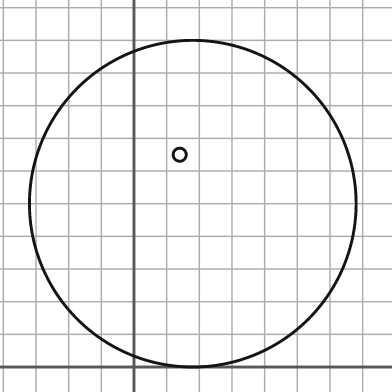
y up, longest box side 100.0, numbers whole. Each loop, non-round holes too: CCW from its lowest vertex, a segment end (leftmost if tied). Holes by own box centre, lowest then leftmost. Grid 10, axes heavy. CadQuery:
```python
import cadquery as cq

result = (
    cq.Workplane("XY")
    .moveTo(18.0, 50.0)
    .circle(50.0)
    .moveTo(14.0, 65.0)
    .circle(2.0)
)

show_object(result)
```